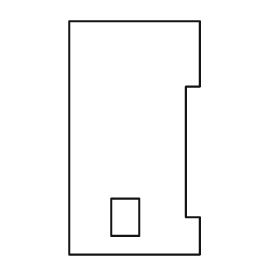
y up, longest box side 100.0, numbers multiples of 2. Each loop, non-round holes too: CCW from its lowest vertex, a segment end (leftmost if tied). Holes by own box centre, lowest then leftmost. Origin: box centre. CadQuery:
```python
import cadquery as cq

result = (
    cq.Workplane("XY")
    .moveTo(-28.0, -50.0)
    .lineTo(28.0, -50.0)
    .lineTo(28.0, -34.0)
    .lineTo(22.0, -34.0)
    .lineTo(22.0, 22.0)
    .lineTo(28.0, 22.0)
    .lineTo(28.0, 50.0)
    .lineTo(-28.0, 50.0)
    .close()
    .moveTo(-10.0, -42.0)
    .lineTo(2.0, -42.0)
    .lineTo(2.0, -26.0)
    .lineTo(-10.0, -26.0)
    .close()
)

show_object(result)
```